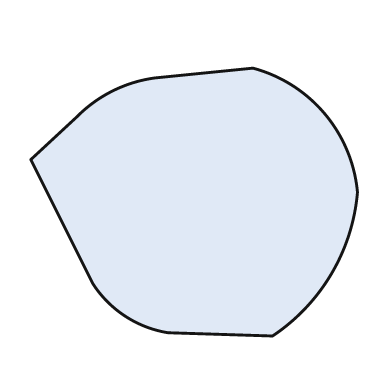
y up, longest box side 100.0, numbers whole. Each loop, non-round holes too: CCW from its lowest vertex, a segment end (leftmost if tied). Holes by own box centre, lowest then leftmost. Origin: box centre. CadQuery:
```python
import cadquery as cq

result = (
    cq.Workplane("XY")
    .moveTo(24.0, -41.0)
    .threePointArc((42.0, -22.0), (50.0, 3.0))
    .threePointArc((40.0, 27.0), (18.0, 41.0))
    .lineTo(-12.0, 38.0)
    .threePointArc((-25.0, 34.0), (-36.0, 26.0))
    .lineTo(-50.0, 13.0)
    .lineTo(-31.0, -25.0)
    .threePointArc((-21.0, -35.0), (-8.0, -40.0))
    .close()
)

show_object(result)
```